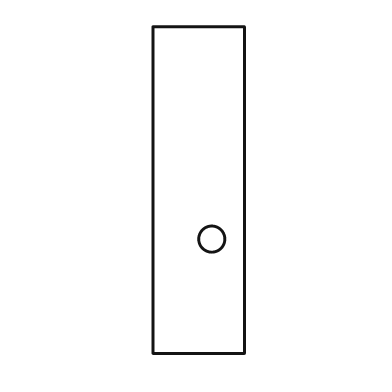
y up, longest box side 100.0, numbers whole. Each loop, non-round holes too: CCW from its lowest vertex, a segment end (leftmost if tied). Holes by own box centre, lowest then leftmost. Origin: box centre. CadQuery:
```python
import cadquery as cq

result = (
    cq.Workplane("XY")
    .moveTo(-14.0, -50.0)
    .lineTo(14.0, -50.0)
    .lineTo(14.0, 50.0)
    .lineTo(-14.0, 50.0)
    .close()
    .moveTo(4.0, -15.0)
    .circle(4.0)
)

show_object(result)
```